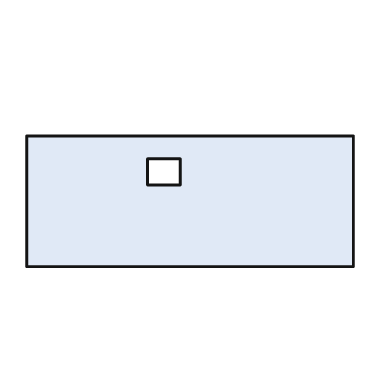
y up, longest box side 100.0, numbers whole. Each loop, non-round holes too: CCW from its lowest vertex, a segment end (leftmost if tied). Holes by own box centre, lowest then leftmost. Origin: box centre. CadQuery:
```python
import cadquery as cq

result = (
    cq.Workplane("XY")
    .moveTo(-50.0, -20.0)
    .lineTo(50.0, -20.0)
    .lineTo(50.0, 20.0)
    .lineTo(-50.0, 20.0)
    .close()
    .moveTo(-13.0, 5.0)
    .lineTo(-3.0, 5.0)
    .lineTo(-3.0, 13.0)
    .lineTo(-13.0, 13.0)
    .close()
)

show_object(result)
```